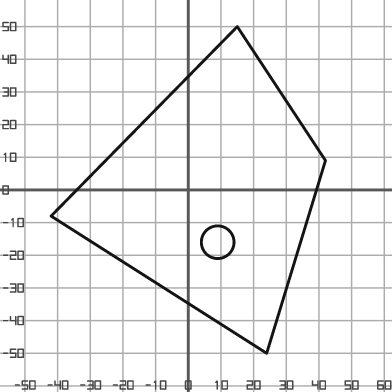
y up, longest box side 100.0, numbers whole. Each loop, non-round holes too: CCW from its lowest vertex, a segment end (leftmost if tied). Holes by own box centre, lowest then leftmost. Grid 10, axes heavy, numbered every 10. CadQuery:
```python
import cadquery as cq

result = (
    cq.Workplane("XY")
    .moveTo(24.0, -50.0)
    .lineTo(42.0, 9.0)
    .lineTo(15.0, 50.0)
    .lineTo(-42.0, -8.0)
    .close()
    .moveTo(9.0, -16.0)
    .circle(5.0)
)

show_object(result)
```